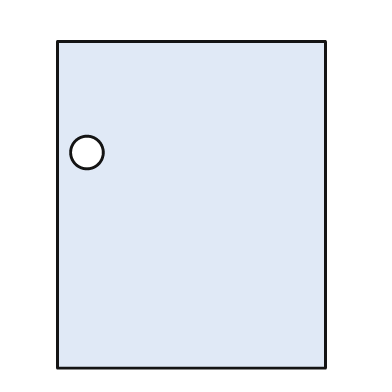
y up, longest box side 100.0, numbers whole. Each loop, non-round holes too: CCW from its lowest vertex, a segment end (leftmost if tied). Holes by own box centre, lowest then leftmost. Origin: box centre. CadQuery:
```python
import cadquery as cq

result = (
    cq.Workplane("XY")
    .moveTo(-41.0, -50.0)
    .lineTo(41.0, -50.0)
    .lineTo(41.0, 50.0)
    .lineTo(-41.0, 50.0)
    .close()
    .moveTo(-32.0, 16.0)
    .circle(5.0)
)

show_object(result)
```